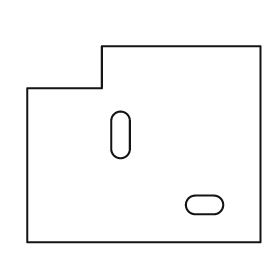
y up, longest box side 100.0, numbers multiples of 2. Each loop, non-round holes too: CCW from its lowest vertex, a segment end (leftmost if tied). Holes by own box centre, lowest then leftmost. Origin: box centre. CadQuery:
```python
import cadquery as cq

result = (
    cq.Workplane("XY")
    .moveTo(-50.0, -42.0)
    .lineTo(50.0, -42.0)
    .lineTo(50.0, 42.0)
    .lineTo(-18.0, 42.0)
    .lineTo(-18.0, 24.0)
    .lineTo(-50.0, 24.0)
    .close()
    .moveTo(22.0, -30.0)
    .lineTo(30.0, -30.0)
    .threePointArc((34.0, -26.0), (30.0, -22.0))
    .lineTo(22.0, -22.0)
    .threePointArc((18.0, -26.0), (22.0, -30.0))
    .close()
    .moveTo(-14.0, -2.0)
    .threePointArc((-10.0, -6.0), (-6.0, -2.0))
    .lineTo(-6.0, 10.0)
    .threePointArc((-10.0, 14.0), (-14.0, 10.0))
    .close()
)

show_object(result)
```